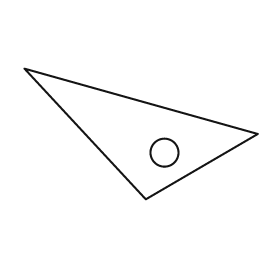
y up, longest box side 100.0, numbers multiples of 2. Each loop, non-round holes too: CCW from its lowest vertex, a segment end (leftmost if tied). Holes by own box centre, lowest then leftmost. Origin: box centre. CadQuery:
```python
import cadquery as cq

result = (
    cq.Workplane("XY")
    .moveTo(2.0, -28.0)
    .lineTo(50.0, 0.0)
    .lineTo(-50.0, 28.0)
    .close()
    .moveTo(10.0, -8.0)
    .circle(6.0)
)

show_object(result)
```